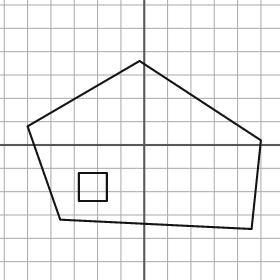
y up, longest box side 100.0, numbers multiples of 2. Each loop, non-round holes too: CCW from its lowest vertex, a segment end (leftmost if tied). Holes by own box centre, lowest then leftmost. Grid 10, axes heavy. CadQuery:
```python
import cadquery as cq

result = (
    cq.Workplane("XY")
    .moveTo(46.0, -36.0)
    .lineTo(50.0, 2.0)
    .lineTo(-2.0, 36.0)
    .lineTo(-50.0, 8.0)
    .lineTo(-36.0, -32.0)
    .close()
    .moveTo(-28.0, -24.0)
    .lineTo(-16.0, -24.0)
    .lineTo(-16.0, -12.0)
    .lineTo(-28.0, -12.0)
    .close()
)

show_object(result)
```